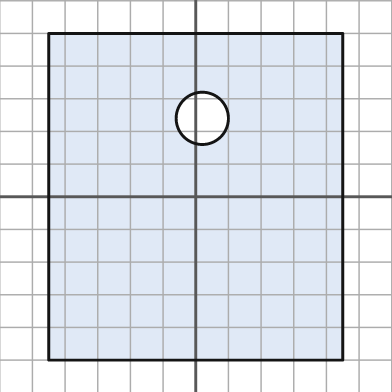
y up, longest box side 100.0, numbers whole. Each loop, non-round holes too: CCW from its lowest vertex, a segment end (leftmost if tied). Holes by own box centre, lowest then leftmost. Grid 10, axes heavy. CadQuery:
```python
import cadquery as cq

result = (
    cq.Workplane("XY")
    .moveTo(-45.0, -50.0)
    .lineTo(45.0, -50.0)
    .lineTo(45.0, 50.0)
    .lineTo(-45.0, 50.0)
    .close()
    .moveTo(2.0, 24.0)
    .circle(8.0)
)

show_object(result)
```